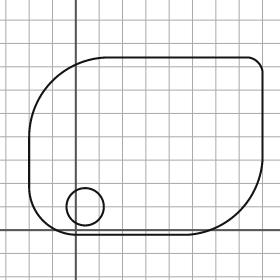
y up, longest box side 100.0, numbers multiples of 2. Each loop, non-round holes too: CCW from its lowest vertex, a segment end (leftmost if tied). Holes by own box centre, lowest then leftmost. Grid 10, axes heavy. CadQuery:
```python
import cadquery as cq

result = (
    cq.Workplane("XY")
    .moveTo(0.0, -2.0)
    .lineTo(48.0, -2.0)
    .threePointArc((70.0, 8.0), (80.0, 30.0))
    .lineTo(80.0, 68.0)
    .threePointArc((78.0, 72.0), (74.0, 74.0))
    .lineTo(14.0, 74.0)
    .threePointArc((-10.0, 64.0), (-20.0, 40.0))
    .lineTo(-20.0, 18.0)
    .threePointArc((-14.0, 4.0), (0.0, -2.0))
    .close()
    .moveTo(4.0, 10.0)
    .circle(8.0)
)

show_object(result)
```